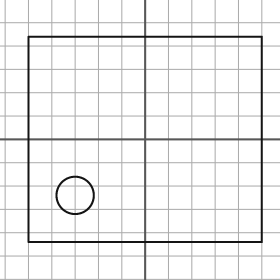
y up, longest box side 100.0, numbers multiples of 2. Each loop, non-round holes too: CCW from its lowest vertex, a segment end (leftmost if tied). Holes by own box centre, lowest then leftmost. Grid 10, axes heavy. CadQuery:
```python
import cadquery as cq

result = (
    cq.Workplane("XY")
    .moveTo(-50.0, -44.0)
    .lineTo(50.0, -44.0)
    .lineTo(50.0, 44.0)
    .lineTo(-50.0, 44.0)
    .close()
    .moveTo(-30.0, -24.0)
    .circle(8.0)
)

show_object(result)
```